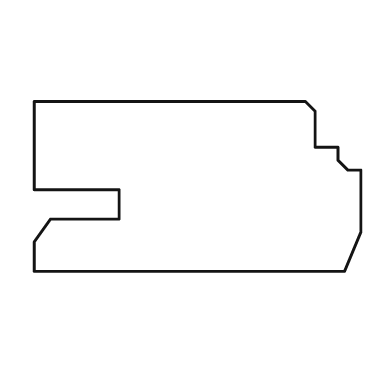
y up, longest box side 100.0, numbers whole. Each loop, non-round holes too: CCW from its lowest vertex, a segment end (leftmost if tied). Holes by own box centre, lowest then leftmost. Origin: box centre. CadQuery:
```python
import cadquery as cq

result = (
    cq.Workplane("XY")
    .moveTo(-50.0, -26.0)
    .lineTo(45.0, -26.0)
    .lineTo(50.0, -14.0)
    .lineTo(50.0, 5.0)
    .lineTo(46.0, 5.0)
    .lineTo(43.0, 8.0)
    .lineTo(43.0, 12.0)
    .lineTo(36.0, 12.0)
    .lineTo(36.0, 23.0)
    .lineTo(33.0, 26.0)
    .lineTo(-50.0, 26.0)
    .lineTo(-50.0, -1.0)
    .lineTo(-24.0, -1.0)
    .lineTo(-24.0, -10.0)
    .lineTo(-45.0, -10.0)
    .lineTo(-50.0, -17.0)
    .close()
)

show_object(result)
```